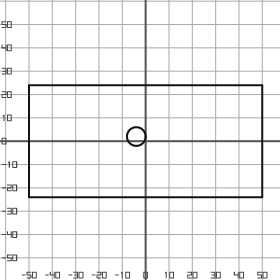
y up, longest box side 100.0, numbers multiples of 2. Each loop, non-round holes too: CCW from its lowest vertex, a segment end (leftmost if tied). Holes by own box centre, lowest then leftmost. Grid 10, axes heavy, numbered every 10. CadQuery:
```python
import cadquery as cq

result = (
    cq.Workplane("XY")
    .moveTo(-50.0, -24.0)
    .lineTo(50.0, -24.0)
    .lineTo(50.0, 24.0)
    .lineTo(-50.0, 24.0)
    .close()
    .moveTo(-4.0, 2.0)
    .circle(4.0)
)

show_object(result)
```